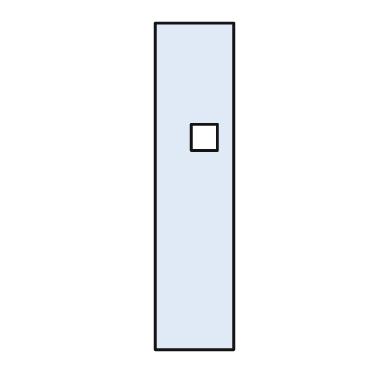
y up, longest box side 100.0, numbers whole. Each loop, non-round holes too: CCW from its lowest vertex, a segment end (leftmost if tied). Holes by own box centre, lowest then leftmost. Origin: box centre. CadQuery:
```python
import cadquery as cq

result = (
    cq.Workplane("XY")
    .moveTo(-12.0, -50.0)
    .lineTo(12.0, -50.0)
    .lineTo(12.0, 50.0)
    .lineTo(-12.0, 50.0)
    .close()
    .moveTo(-1.0, 11.0)
    .lineTo(7.0, 11.0)
    .lineTo(7.0, 19.0)
    .lineTo(-1.0, 19.0)
    .close()
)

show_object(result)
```